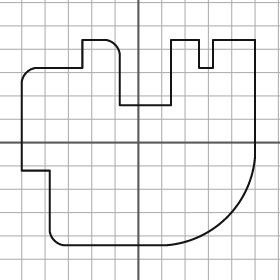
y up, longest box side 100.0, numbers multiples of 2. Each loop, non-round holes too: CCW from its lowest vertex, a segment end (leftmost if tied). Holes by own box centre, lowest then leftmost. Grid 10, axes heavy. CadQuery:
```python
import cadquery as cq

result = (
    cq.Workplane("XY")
    .moveTo(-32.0, -44.0)
    .lineTo(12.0, -44.0)
    .threePointArc((38.0, -32.0), (50.0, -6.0))
    .lineTo(50.0, 44.0)
    .lineTo(32.0, 44.0)
    .lineTo(32.0, 32.0)
    .lineTo(26.0, 32.0)
    .lineTo(26.0, 44.0)
    .lineTo(14.0, 44.0)
    .lineTo(14.0, 16.0)
    .lineTo(-8.0, 16.0)
    .lineTo(-8.0, 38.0)
    .threePointArc((-10.0, 42.0), (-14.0, 44.0))
    .lineTo(-24.0, 44.0)
    .lineTo(-24.0, 32.0)
    .lineTo(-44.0, 32.0)
    .threePointArc((-48.0, 30.0), (-50.0, 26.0))
    .lineTo(-50.0, -12.0)
    .lineTo(-38.0, -12.0)
    .lineTo(-38.0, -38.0)
    .threePointArc((-36.0, -42.0), (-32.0, -44.0))
    .close()
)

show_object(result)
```